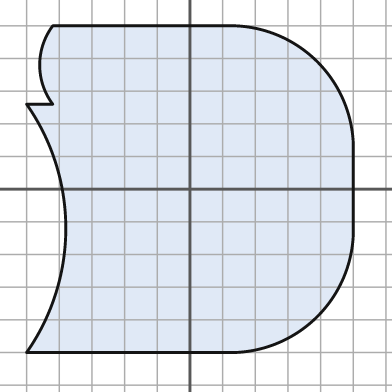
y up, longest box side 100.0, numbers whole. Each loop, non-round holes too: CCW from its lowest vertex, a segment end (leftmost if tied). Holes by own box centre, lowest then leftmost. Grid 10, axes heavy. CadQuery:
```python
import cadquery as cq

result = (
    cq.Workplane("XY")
    .moveTo(-50.0, -50.0)
    .lineTo(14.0, -50.0)
    .threePointArc((39.0, -39.0), (50.0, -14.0))
    .lineTo(50.0, 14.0)
    .threePointArc((39.0, 39.0), (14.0, 50.0))
    .lineTo(-42.0, 50.0)
    .threePointArc((-46.0, 38.0), (-42.0, 26.0))
    .lineTo(-50.0, 26.0)
    .threePointArc((-38.0, -12.0), (-50.0, -50.0))
    .close()
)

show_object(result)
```